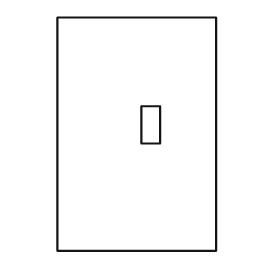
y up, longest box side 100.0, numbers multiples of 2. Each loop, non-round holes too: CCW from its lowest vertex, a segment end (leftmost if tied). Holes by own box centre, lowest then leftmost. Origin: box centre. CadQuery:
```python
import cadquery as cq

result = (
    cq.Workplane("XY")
    .moveTo(-34.0, -50.0)
    .lineTo(34.0, -50.0)
    .lineTo(34.0, 50.0)
    .lineTo(-34.0, 50.0)
    .close()
    .moveTo(2.0, -4.0)
    .lineTo(10.0, -4.0)
    .lineTo(10.0, 12.0)
    .lineTo(2.0, 12.0)
    .close()
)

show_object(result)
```